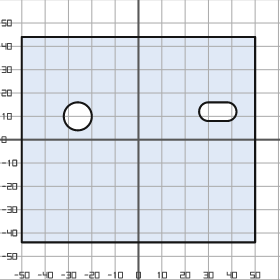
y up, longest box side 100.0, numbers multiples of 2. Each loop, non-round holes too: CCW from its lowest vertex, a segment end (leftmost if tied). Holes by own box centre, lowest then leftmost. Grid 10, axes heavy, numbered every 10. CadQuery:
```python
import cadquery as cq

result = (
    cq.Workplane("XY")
    .moveTo(-50.0, -44.0)
    .lineTo(50.0, -44.0)
    .lineTo(50.0, 44.0)
    .lineTo(-50.0, 44.0)
    .close()
    .moveTo(-26.0, 10.0)
    .circle(6.0)
    .moveTo(30.0, 8.0)
    .lineTo(38.0, 8.0)
    .threePointArc((42.0, 12.0), (38.0, 16.0))
    .lineTo(30.0, 16.0)
    .threePointArc((26.0, 12.0), (30.0, 8.0))
    .close()
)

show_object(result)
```